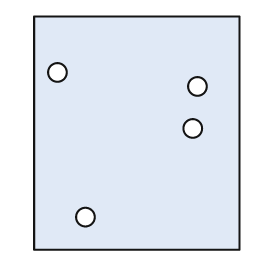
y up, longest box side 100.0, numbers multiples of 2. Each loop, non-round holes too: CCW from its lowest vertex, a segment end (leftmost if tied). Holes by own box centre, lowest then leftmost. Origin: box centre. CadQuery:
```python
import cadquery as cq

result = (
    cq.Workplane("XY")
    .moveTo(-44.0, -50.0)
    .lineTo(44.0, -50.0)
    .lineTo(44.0, 50.0)
    .lineTo(-44.0, 50.0)
    .close()
    .moveTo(-22.0, -36.0)
    .circle(4.0)
    .moveTo(24.0, 2.0)
    .circle(4.0)
    .moveTo(26.0, 20.0)
    .circle(4.0)
    .moveTo(-34.0, 26.0)
    .circle(4.0)
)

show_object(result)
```